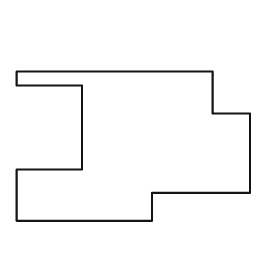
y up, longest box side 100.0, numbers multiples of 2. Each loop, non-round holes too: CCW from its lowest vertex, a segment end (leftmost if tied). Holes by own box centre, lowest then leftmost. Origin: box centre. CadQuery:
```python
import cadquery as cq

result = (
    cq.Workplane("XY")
    .moveTo(-50.0, -32.0)
    .lineTo(8.0, -32.0)
    .lineTo(8.0, -20.0)
    .lineTo(50.0, -20.0)
    .lineTo(50.0, 14.0)
    .lineTo(34.0, 14.0)
    .lineTo(34.0, 32.0)
    .lineTo(-50.0, 32.0)
    .lineTo(-50.0, 26.0)
    .lineTo(-22.0, 26.0)
    .lineTo(-22.0, -10.0)
    .lineTo(-50.0, -10.0)
    .close()
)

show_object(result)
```